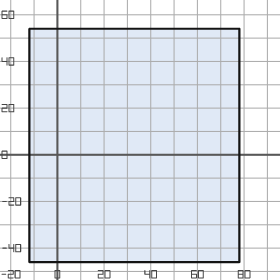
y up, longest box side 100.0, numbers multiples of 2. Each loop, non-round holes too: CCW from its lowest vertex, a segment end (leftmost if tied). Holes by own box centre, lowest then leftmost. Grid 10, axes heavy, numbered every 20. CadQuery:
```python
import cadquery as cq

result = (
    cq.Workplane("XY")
    .moveTo(-12.0, -46.0)
    .lineTo(78.0, -46.0)
    .lineTo(78.0, 54.0)
    .lineTo(-12.0, 54.0)
    .close()
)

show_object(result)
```